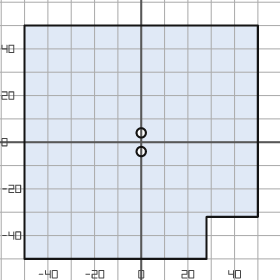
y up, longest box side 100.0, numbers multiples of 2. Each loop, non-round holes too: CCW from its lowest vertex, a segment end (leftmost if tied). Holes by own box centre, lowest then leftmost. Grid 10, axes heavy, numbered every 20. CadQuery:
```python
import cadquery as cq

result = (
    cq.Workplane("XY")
    .moveTo(-50.0, -50.0)
    .lineTo(28.0, -50.0)
    .lineTo(28.0, -32.0)
    .lineTo(50.0, -32.0)
    .lineTo(50.0, 50.0)
    .lineTo(-50.0, 50.0)
    .close()
    .moveTo(0.0, -4.0)
    .circle(2.0)
    .moveTo(0.0, 4.0)
    .circle(2.0)
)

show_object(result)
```